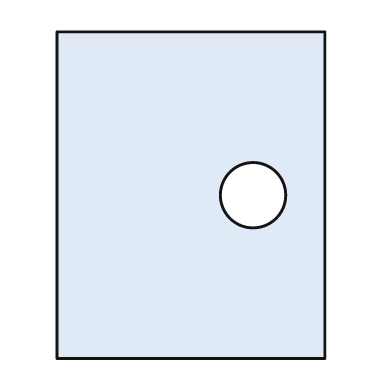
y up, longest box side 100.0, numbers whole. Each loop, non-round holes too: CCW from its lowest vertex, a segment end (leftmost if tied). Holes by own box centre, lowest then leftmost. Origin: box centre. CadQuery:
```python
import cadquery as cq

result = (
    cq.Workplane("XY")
    .moveTo(-41.0, -50.0)
    .lineTo(41.0, -50.0)
    .lineTo(41.0, 50.0)
    .lineTo(-41.0, 50.0)
    .close()
    .moveTo(19.0, 0.0)
    .circle(10.0)
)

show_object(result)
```